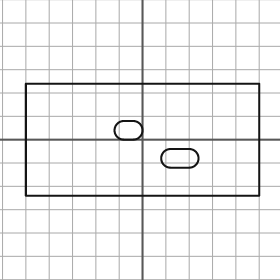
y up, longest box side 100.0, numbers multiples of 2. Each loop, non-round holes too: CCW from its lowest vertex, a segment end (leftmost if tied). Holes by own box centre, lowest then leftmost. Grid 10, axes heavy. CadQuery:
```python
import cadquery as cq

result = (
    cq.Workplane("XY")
    .moveTo(-50.0, -24.0)
    .lineTo(50.0, -24.0)
    .lineTo(50.0, 24.0)
    .lineTo(-50.0, 24.0)
    .close()
    .moveTo(12.0, -12.0)
    .lineTo(20.0, -12.0)
    .threePointArc((24.0, -8.0), (20.0, -4.0))
    .lineTo(12.0, -4.0)
    .threePointArc((8.0, -8.0), (12.0, -12.0))
    .close()
    .moveTo(-8.0, 0.0)
    .lineTo(-4.0, 0.0)
    .threePointArc((0.0, 4.0), (-4.0, 8.0))
    .lineTo(-8.0, 8.0)
    .threePointArc((-12.0, 4.0), (-8.0, 0.0))
    .close()
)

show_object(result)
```